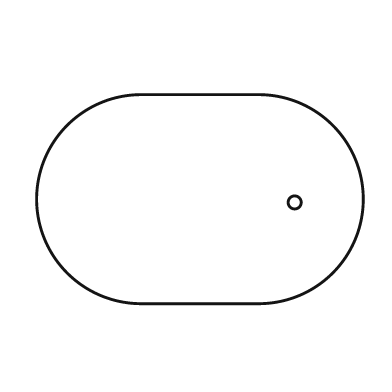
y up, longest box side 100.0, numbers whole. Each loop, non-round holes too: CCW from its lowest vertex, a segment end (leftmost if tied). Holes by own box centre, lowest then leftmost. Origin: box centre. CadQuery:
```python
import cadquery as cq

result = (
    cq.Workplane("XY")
    .moveTo(-18.0, -32.0)
    .lineTo(18.0, -32.0)
    .threePointArc((50.0, 0.0), (18.0, 32.0))
    .lineTo(-18.0, 32.0)
    .threePointArc((-50.0, 0.0), (-18.0, -32.0))
    .close()
    .moveTo(29.0, -1.0)
    .circle(2.0)
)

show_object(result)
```